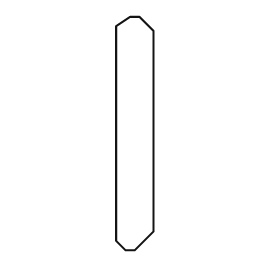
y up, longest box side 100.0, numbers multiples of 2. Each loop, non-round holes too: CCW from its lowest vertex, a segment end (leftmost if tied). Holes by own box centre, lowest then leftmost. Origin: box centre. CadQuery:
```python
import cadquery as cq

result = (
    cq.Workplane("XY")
    .moveTo(-4.0, -50.0)
    .lineTo(0.0, -50.0)
    .lineTo(8.0, -42.0)
    .lineTo(8.0, 44.0)
    .lineTo(2.0, 50.0)
    .lineTo(-2.0, 50.0)
    .lineTo(-8.0, 46.0)
    .lineTo(-8.0, -46.0)
    .close()
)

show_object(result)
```